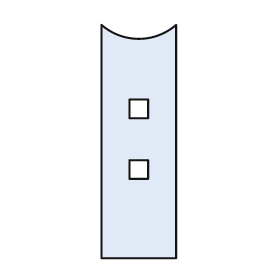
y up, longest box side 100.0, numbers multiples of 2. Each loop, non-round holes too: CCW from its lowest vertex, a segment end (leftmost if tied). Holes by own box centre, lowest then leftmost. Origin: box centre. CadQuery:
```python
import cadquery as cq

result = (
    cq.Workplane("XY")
    .moveTo(-16.0, -50.0)
    .lineTo(16.0, -50.0)
    .lineTo(16.0, 50.0)
    .threePointArc((0.0, 44.0), (-16.0, 50.0))
    .close()
    .moveTo(-4.0, -16.0)
    .lineTo(4.0, -16.0)
    .lineTo(4.0, -8.0)
    .lineTo(-4.0, -8.0)
    .close()
    .moveTo(-4.0, 10.0)
    .lineTo(4.0, 10.0)
    .lineTo(4.0, 18.0)
    .lineTo(-4.0, 18.0)
    .close()
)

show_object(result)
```